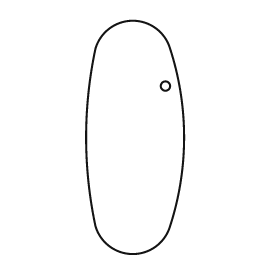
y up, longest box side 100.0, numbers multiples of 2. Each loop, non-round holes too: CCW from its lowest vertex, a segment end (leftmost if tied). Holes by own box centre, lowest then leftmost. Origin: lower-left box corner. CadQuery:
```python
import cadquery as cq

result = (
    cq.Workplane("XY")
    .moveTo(4.0, 12.0)
    .threePointArc((20.0, 0.0), (36.0, 12.0))
    .threePointArc((42.0, 50.0), (36.0, 88.0))
    .threePointArc((20.0, 100.0), (4.0, 88.0))
    .threePointArc((0.0, 50.0), (4.0, 12.0))
    .close()
    .moveTo(34.0, 72.0)
    .circle(2.0)
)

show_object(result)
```